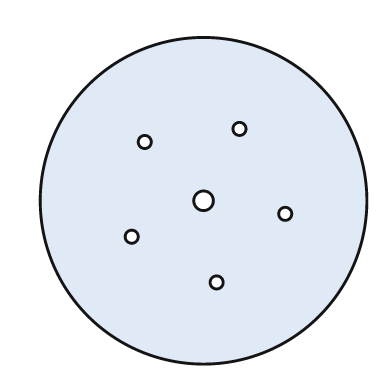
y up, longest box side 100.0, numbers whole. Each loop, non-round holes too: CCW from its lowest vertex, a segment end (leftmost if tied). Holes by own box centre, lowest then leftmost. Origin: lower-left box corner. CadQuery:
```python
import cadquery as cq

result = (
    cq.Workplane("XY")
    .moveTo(50.0, 50.0)
    .circle(50.0)
    .moveTo(54.0, 25.0)
    .circle(2.0)
    .moveTo(28.0, 39.0)
    .circle(2.0)
    .moveTo(75.0, 46.0)
    .circle(2.0)
    .moveTo(50.0, 50.0)
    .circle(3.0)
    .moveTo(32.0, 68.0)
    .circle(2.0)
    .moveTo(61.0, 72.0)
    .circle(2.0)
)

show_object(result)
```